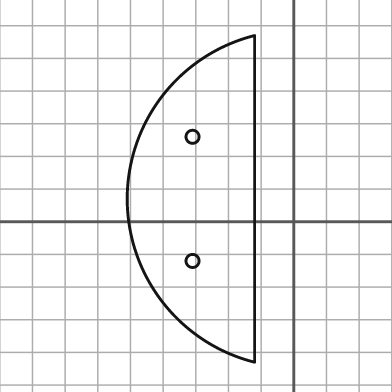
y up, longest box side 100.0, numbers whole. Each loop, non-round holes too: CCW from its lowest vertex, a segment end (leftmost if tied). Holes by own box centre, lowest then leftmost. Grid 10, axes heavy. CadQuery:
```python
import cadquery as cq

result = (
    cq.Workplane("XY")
    .moveTo(-12.0, -43.0)
    .lineTo(-12.0, 57.0)
    .threePointArc((-51.0, 7.0), (-12.0, -43.0))
    .close()
    .moveTo(-31.0, -12.0)
    .circle(2.0)
    .moveTo(-31.0, 26.0)
    .circle(2.0)
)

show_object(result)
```